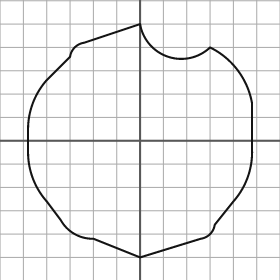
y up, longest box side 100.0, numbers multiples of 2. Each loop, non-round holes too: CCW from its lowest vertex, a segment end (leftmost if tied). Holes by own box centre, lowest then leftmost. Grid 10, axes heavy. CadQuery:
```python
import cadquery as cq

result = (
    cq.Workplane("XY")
    .moveTo(0.0, -50.0)
    .lineTo(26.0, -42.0)
    .threePointArc((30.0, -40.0), (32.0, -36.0))
    .lineTo(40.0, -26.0)
    .threePointArc((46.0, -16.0), (48.0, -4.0))
    .lineTo(48.0, 16.0)
    .threePointArc((42.0, 30.0), (30.0, 40.0))
    .threePointArc((12.0, 36.0), (0.0, 50.0))
    .lineTo(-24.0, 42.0)
    .threePointArc((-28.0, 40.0), (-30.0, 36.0))
    .lineTo(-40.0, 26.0)
    .threePointArc((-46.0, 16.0), (-48.0, 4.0))
    .lineTo(-48.0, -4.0)
    .threePointArc((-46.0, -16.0), (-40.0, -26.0))
    .lineTo(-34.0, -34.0)
    .threePointArc((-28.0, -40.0), (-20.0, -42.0))
    .close()
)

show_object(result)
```